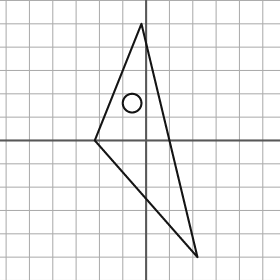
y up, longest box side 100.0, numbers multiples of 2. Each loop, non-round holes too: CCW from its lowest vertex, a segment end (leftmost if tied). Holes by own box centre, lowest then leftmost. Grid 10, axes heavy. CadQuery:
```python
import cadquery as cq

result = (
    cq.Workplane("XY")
    .moveTo(22.0, -50.0)
    .lineTo(-2.0, 50.0)
    .lineTo(-22.0, 0.0)
    .close()
    .moveTo(-6.0, 16.0)
    .circle(4.0)
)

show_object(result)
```